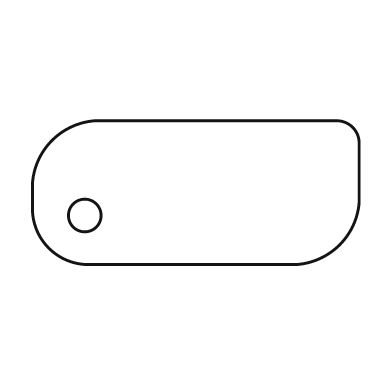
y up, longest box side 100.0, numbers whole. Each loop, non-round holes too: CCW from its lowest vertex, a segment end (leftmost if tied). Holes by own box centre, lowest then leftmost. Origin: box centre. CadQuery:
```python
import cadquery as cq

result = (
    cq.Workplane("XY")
    .moveTo(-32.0, -22.0)
    .lineTo(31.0, -22.0)
    .threePointArc((44.0, -16.0), (50.0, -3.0))
    .lineTo(50.0, 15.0)
    .threePointArc((48.0, 20.0), (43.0, 22.0))
    .lineTo(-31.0, 22.0)
    .threePointArc((-44.0, 16.0), (-50.0, 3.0))
    .lineTo(-50.0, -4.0)
    .threePointArc((-45.0, -17.0), (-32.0, -22.0))
    .close()
    .moveTo(-34.0, -7.0)
    .circle(5.0)
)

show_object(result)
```